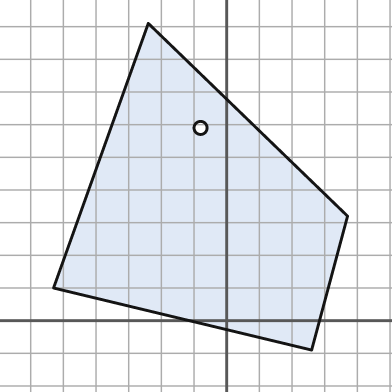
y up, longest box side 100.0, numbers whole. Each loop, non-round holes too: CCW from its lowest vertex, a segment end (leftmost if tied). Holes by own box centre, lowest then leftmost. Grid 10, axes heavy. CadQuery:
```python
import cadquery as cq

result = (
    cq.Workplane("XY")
    .moveTo(26.0, -9.0)
    .lineTo(37.0, 32.0)
    .lineTo(-24.0, 91.0)
    .lineTo(-53.0, 10.0)
    .close()
    .moveTo(-8.0, 59.0)
    .circle(2.0)
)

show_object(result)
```